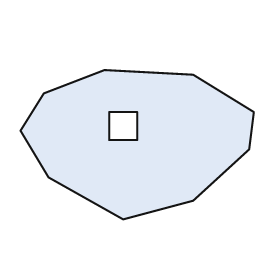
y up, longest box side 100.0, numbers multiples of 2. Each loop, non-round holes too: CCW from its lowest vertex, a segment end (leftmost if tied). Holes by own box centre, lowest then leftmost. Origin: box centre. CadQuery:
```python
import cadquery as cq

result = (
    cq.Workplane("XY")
    .moveTo(-6.0, -32.0)
    .lineTo(24.0, -24.0)
    .lineTo(48.0, -2.0)
    .lineTo(50.0, 14.0)
    .lineTo(24.0, 30.0)
    .lineTo(-14.0, 32.0)
    .lineTo(-40.0, 22.0)
    .lineTo(-50.0, 6.0)
    .lineTo(-38.0, -14.0)
    .close()
    .moveTo(-12.0, 2.0)
    .lineTo(0.0, 2.0)
    .lineTo(0.0, 14.0)
    .lineTo(-12.0, 14.0)
    .close()
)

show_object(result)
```